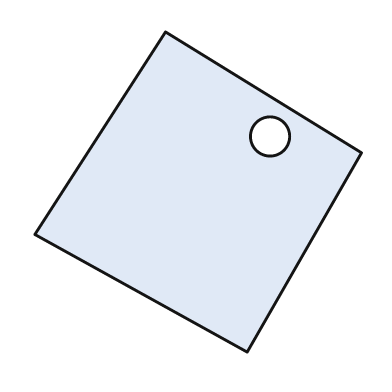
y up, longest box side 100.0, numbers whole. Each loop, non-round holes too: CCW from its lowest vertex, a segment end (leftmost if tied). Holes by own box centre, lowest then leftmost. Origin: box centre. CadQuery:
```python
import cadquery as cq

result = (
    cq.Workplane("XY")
    .moveTo(15.0, -49.0)
    .lineTo(50.0, 12.0)
    .lineTo(-10.0, 49.0)
    .lineTo(-50.0, -13.0)
    .close()
    .moveTo(22.0, 17.0)
    .circle(6.0)
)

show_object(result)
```